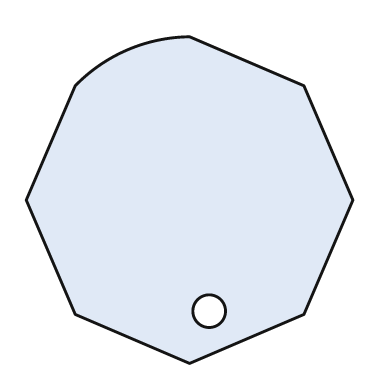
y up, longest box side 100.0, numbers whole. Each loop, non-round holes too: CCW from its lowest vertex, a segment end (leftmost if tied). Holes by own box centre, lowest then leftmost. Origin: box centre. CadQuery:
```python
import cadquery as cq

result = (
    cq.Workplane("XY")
    .moveTo(0.0, -50.0)
    .lineTo(35.0, -35.0)
    .lineTo(50.0, 0.0)
    .lineTo(35.0, 35.0)
    .lineTo(0.0, 50.0)
    .threePointArc((-19.0, 46.0), (-35.0, 35.0))
    .lineTo(-50.0, 0.0)
    .lineTo(-35.0, -35.0)
    .close()
    .moveTo(6.0, -34.0)
    .circle(5.0)
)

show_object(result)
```